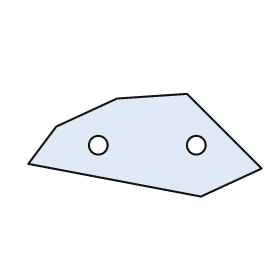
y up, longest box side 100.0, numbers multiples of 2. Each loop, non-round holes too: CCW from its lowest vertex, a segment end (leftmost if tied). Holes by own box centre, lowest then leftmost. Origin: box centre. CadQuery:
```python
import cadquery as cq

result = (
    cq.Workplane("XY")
    .moveTo(24.0, -22.0)
    .lineTo(50.0, -10.0)
    .lineTo(18.0, 22.0)
    .lineTo(-12.0, 20.0)
    .lineTo(-38.0, 8.0)
    .lineTo(-50.0, -8.0)
    .close()
    .moveTo(-20.0, 0.0)
    .circle(4.0)
    .moveTo(22.0, 0.0)
    .circle(4.0)
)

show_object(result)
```